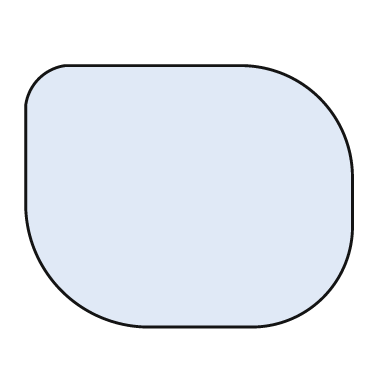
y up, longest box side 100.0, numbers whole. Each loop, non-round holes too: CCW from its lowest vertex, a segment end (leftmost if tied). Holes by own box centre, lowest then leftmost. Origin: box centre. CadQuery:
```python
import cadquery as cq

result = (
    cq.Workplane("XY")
    .moveTo(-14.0, -40.0)
    .lineTo(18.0, -40.0)
    .threePointArc((41.0, -31.0), (50.0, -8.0))
    .lineTo(50.0, 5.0)
    .threePointArc((40.0, 30.0), (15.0, 40.0))
    .lineTo(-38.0, 40.0)
    .threePointArc((-46.0, 36.0), (-50.0, 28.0))
    .lineTo(-50.0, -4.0)
    .threePointArc((-39.0, -29.0), (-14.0, -40.0))
    .close()
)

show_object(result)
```